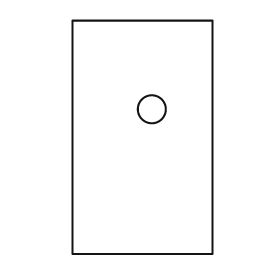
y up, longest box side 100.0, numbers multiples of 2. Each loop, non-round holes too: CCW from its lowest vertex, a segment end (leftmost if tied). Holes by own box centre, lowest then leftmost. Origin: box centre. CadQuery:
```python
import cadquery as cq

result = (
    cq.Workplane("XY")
    .moveTo(-30.0, -50.0)
    .lineTo(30.0, -50.0)
    .lineTo(30.0, 50.0)
    .lineTo(-30.0, 50.0)
    .close()
    .moveTo(4.0, 12.0)
    .circle(6.0)
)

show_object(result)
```